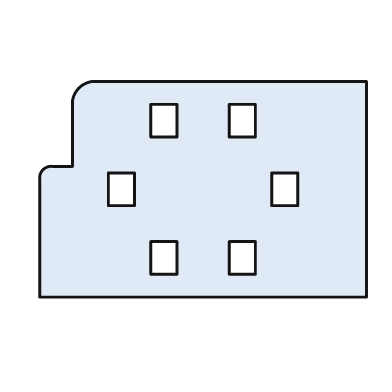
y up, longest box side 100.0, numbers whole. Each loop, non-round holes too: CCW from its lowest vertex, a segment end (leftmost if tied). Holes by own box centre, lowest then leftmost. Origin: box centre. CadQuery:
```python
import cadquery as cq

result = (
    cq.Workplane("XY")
    .moveTo(-50.0, -33.0)
    .lineTo(50.0, -33.0)
    .lineTo(50.0, 33.0)
    .lineTo(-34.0, 33.0)
    .threePointArc((-38.0, 31.0), (-40.0, 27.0))
    .lineTo(-40.0, 7.0)
    .lineTo(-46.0, 7.0)
    .threePointArc((-49.0, 6.0), (-50.0, 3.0))
    .close()
    .moveTo(-16.0, -26.0)
    .lineTo(-8.0, -26.0)
    .lineTo(-8.0, -16.0)
    .lineTo(-16.0, -16.0)
    .close()
    .moveTo(8.0, -26.0)
    .lineTo(16.0, -26.0)
    .lineTo(16.0, -16.0)
    .lineTo(8.0, -16.0)
    .close()
    .moveTo(-29.0, -5.0)
    .lineTo(-21.0, -5.0)
    .lineTo(-21.0, 5.0)
    .lineTo(-29.0, 5.0)
    .close()
    .moveTo(21.0, -5.0)
    .lineTo(29.0, -5.0)
    .lineTo(29.0, 5.0)
    .lineTo(21.0, 5.0)
    .close()
    .moveTo(-16.0, 16.0)
    .lineTo(-8.0, 16.0)
    .lineTo(-8.0, 26.0)
    .lineTo(-16.0, 26.0)
    .close()
    .moveTo(8.0, 16.0)
    .lineTo(16.0, 16.0)
    .lineTo(16.0, 26.0)
    .lineTo(8.0, 26.0)
    .close()
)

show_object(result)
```